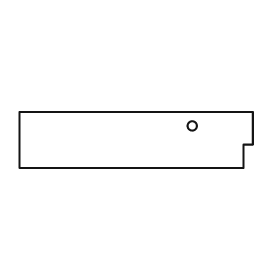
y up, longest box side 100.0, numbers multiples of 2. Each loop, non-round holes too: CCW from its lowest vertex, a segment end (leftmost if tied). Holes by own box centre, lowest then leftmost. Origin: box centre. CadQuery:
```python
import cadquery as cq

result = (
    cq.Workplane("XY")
    .moveTo(-50.0, -12.0)
    .lineTo(46.0, -12.0)
    .lineTo(46.0, -2.0)
    .lineTo(50.0, -2.0)
    .lineTo(50.0, 12.0)
    .lineTo(-50.0, 12.0)
    .close()
    .moveTo(24.0, 6.0)
    .circle(2.0)
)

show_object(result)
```